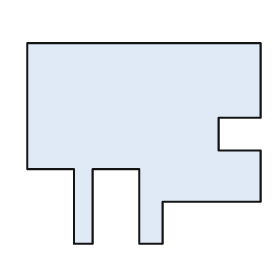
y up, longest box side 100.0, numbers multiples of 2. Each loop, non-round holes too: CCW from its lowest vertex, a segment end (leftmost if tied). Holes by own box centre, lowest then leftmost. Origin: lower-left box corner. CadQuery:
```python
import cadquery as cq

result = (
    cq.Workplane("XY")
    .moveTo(20.0, 0.0)
    .lineTo(28.0, 0.0)
    .lineTo(28.0, 32.0)
    .lineTo(48.0, 32.0)
    .lineTo(48.0, 0.0)
    .lineTo(58.0, 0.0)
    .lineTo(58.0, 18.0)
    .lineTo(100.0, 18.0)
    .lineTo(100.0, 40.0)
    .lineTo(82.0, 40.0)
    .lineTo(82.0, 54.0)
    .lineTo(100.0, 54.0)
    .lineTo(100.0, 86.0)
    .lineTo(0.0, 86.0)
    .lineTo(0.0, 32.0)
    .lineTo(20.0, 32.0)
    .close()
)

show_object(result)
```